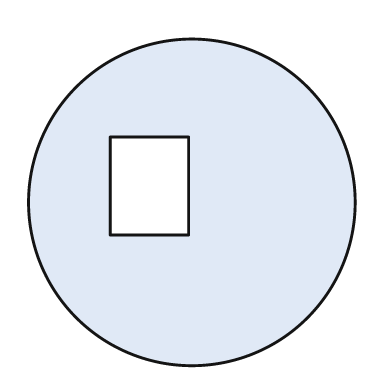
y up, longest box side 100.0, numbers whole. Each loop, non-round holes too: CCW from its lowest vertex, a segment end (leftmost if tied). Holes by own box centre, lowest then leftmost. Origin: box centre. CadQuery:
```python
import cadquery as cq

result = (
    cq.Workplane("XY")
    .moveTo(0.0, 0.0)
    .circle(50.0)
    .moveTo(-25.0, -10.0)
    .lineTo(-1.0, -10.0)
    .lineTo(-1.0, 20.0)
    .lineTo(-25.0, 20.0)
    .close()
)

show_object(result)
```